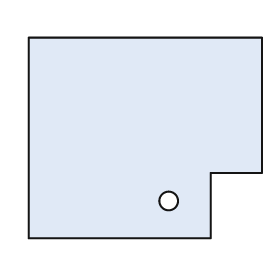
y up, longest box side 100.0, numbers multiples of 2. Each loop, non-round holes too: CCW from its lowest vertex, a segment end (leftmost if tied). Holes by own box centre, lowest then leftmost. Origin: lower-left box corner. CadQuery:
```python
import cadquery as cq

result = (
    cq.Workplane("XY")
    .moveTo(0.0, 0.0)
    .lineTo(78.0, 0.0)
    .lineTo(78.0, 28.0)
    .lineTo(100.0, 28.0)
    .lineTo(100.0, 86.0)
    .lineTo(0.0, 86.0)
    .close()
    .moveTo(60.0, 16.0)
    .circle(4.0)
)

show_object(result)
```